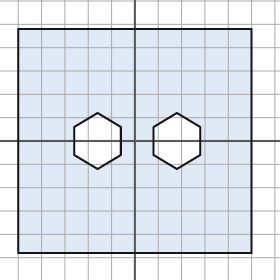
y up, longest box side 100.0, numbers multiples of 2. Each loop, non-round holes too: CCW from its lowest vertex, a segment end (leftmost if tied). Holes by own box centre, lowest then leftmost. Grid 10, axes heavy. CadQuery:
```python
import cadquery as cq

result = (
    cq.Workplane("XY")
    .moveTo(-50.0, -48.0)
    .lineTo(50.0, -48.0)
    .lineTo(50.0, 48.0)
    .lineTo(-50.0, 48.0)
    .close()
    .moveTo(-16.0, -12.0)
    .lineTo(-6.0, -6.0)
    .lineTo(-6.0, 6.0)
    .lineTo(-16.0, 12.0)
    .lineTo(-26.0, 6.0)
    .lineTo(-26.0, -6.0)
    .close()
    .moveTo(18.0, -12.0)
    .lineTo(28.0, -6.0)
    .lineTo(28.0, 6.0)
    .lineTo(18.0, 12.0)
    .lineTo(8.0, 6.0)
    .lineTo(8.0, -6.0)
    .close()
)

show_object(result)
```